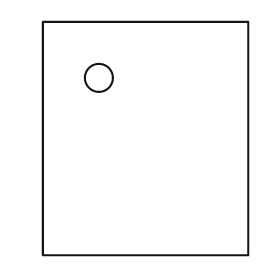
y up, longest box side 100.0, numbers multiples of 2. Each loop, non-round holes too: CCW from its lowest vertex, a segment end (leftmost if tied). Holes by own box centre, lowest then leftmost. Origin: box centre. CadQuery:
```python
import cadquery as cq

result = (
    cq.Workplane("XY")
    .moveTo(-44.0, -50.0)
    .lineTo(44.0, -50.0)
    .lineTo(44.0, 50.0)
    .lineTo(-44.0, 50.0)
    .close()
    .moveTo(-20.0, 26.0)
    .circle(6.0)
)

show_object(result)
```